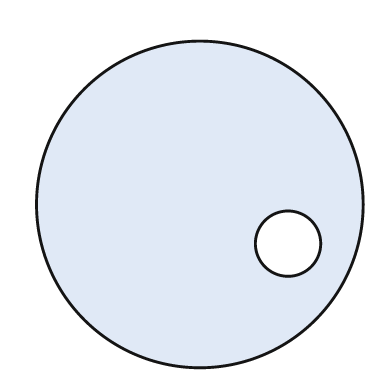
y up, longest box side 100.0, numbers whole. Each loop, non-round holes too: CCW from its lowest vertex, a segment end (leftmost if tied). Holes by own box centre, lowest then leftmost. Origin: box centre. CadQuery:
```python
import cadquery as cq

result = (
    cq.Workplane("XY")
    .moveTo(0.0, 0.0)
    .circle(50.0)
    .moveTo(27.0, -12.0)
    .circle(10.0)
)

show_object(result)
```